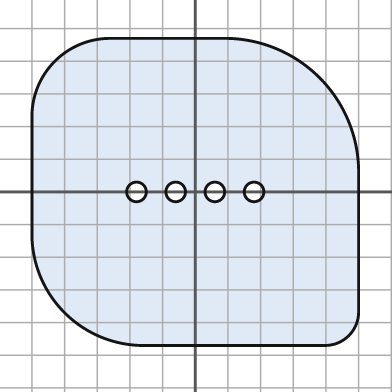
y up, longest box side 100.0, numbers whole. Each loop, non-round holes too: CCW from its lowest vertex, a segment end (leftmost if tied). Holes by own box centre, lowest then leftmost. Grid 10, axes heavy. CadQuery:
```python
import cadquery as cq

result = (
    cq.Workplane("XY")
    .moveTo(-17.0, -47.0)
    .lineTo(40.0, -47.0)
    .threePointArc((47.0, -44.0), (50.0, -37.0))
    .lineTo(50.0, 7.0)
    .threePointArc((38.0, 35.0), (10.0, 47.0))
    .lineTo(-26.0, 47.0)
    .threePointArc((-43.0, 40.0), (-50.0, 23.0))
    .lineTo(-50.0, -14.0)
    .threePointArc((-40.0, -37.0), (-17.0, -47.0))
    .close()
    .moveTo(-18.0, 0.0)
    .circle(3.0)
    .moveTo(-6.0, 0.0)
    .circle(3.0)
    .moveTo(6.0, 0.0)
    .circle(3.0)
    .moveTo(18.0, 0.0)
    .circle(3.0)
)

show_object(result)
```